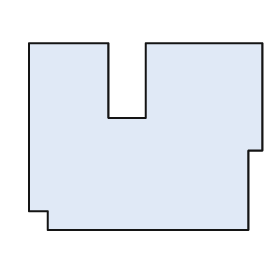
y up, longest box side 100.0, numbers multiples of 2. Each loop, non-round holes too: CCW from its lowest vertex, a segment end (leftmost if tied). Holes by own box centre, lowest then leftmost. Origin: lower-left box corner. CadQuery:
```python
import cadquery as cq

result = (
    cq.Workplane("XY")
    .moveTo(8.0, 0.0)
    .lineTo(94.0, 0.0)
    .lineTo(94.0, 34.0)
    .lineTo(100.0, 34.0)
    .lineTo(100.0, 80.0)
    .lineTo(50.0, 80.0)
    .lineTo(50.0, 48.0)
    .lineTo(34.0, 48.0)
    .lineTo(34.0, 80.0)
    .lineTo(0.0, 80.0)
    .lineTo(0.0, 8.0)
    .lineTo(8.0, 8.0)
    .close()
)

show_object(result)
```